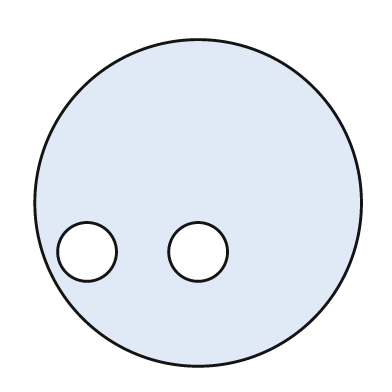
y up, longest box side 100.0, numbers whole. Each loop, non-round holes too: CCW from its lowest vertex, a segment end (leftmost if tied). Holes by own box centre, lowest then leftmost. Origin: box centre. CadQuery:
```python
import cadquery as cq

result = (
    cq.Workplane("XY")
    .moveTo(0.0, 0.0)
    .circle(50.0)
    .moveTo(-34.0, -15.0)
    .circle(9.0)
    .moveTo(0.0, -15.0)
    .circle(9.0)
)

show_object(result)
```